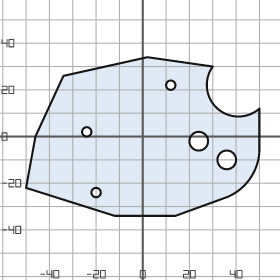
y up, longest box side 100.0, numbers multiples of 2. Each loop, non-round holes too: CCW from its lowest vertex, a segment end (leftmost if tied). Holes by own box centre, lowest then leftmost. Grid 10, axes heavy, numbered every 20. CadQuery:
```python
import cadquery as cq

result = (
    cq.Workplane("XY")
    .moveTo(-12.0, -34.0)
    .lineTo(14.0, -34.0)
    .lineTo(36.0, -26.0)
    .threePointArc((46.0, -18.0), (50.0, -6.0))
    .lineTo(50.0, 12.0)
    .threePointArc((32.0, 12.0), (30.0, 30.0))
    .lineTo(2.0, 34.0)
    .lineTo(-34.0, 26.0)
    .lineTo(-46.0, 0.0)
    .lineTo(-50.0, -22.0)
    .close()
    .moveTo(-20.0, -24.0)
    .circle(2.0)
    .moveTo(36.0, -10.0)
    .circle(4.0)
    .moveTo(24.0, -2.0)
    .circle(4.0)
    .moveTo(-24.0, 2.0)
    .circle(2.0)
    .moveTo(12.0, 22.0)
    .circle(2.0)
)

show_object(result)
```